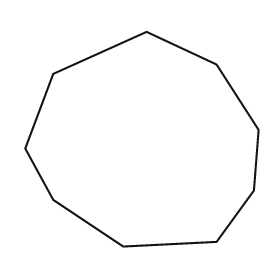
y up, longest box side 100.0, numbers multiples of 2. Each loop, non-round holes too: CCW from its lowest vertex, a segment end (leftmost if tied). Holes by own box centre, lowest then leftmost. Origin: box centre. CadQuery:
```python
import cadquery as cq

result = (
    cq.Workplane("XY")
    .moveTo(-8.0, -46.0)
    .lineTo(32.0, -44.0)
    .lineTo(48.0, -22.0)
    .lineTo(50.0, 4.0)
    .lineTo(32.0, 32.0)
    .lineTo(2.0, 46.0)
    .lineTo(-38.0, 28.0)
    .lineTo(-50.0, -4.0)
    .lineTo(-38.0, -26.0)
    .close()
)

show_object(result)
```